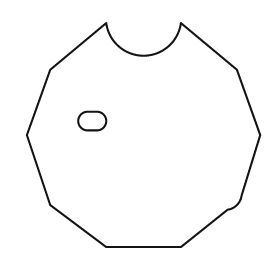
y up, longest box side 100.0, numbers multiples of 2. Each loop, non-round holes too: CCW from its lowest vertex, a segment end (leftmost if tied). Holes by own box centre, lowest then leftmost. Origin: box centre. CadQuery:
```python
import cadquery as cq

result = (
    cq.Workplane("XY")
    .moveTo(-16.0, -48.0)
    .lineTo(16.0, -48.0)
    .lineTo(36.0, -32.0)
    .threePointArc((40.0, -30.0), (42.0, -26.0))
    .lineTo(50.0, 0.0)
    .lineTo(40.0, 28.0)
    .lineTo(16.0, 48.0)
    .threePointArc((0.0, 34.0), (-16.0, 48.0))
    .lineTo(-40.0, 28.0)
    .lineTo(-50.0, 0.0)
    .lineTo(-40.0, -30.0)
    .close()
    .moveTo(-24.0, 2.0)
    .lineTo(-20.0, 2.0)
    .threePointArc((-16.0, 6.0), (-20.0, 10.0))
    .lineTo(-24.0, 10.0)
    .threePointArc((-28.0, 6.0), (-24.0, 2.0))
    .close()
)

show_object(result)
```